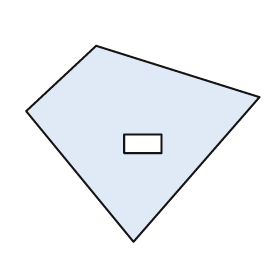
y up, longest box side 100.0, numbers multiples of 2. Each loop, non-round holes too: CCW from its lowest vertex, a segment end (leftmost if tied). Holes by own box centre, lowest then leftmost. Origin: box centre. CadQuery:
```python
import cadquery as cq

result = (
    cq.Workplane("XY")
    .moveTo(-4.0, -42.0)
    .lineTo(50.0, 20.0)
    .lineTo(-20.0, 42.0)
    .lineTo(-50.0, 14.0)
    .close()
    .moveTo(-8.0, -4.0)
    .lineTo(8.0, -4.0)
    .lineTo(8.0, 4.0)
    .lineTo(-8.0, 4.0)
    .close()
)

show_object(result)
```